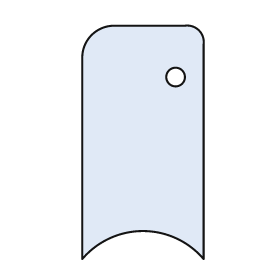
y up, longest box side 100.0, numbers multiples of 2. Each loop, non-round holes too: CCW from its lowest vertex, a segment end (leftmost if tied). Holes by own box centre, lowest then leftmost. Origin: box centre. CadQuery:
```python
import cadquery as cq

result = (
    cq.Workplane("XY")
    .moveTo(-26.0, -50.0)
    .threePointArc((0.0, -38.0), (26.0, -50.0))
    .lineTo(26.0, 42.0)
    .threePointArc((24.0, 48.0), (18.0, 50.0))
    .lineTo(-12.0, 50.0)
    .threePointArc((-22.0, 46.0), (-26.0, 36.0))
    .close()
    .moveTo(14.0, 28.0)
    .circle(4.0)
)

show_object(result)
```